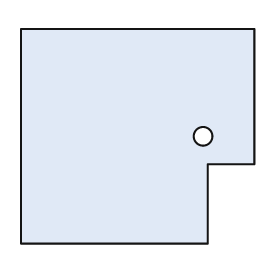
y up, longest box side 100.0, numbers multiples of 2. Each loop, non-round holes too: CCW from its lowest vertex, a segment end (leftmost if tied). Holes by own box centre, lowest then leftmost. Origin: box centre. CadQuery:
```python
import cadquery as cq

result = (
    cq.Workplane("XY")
    .moveTo(-50.0, -46.0)
    .lineTo(30.0, -46.0)
    .lineTo(30.0, -12.0)
    .lineTo(50.0, -12.0)
    .lineTo(50.0, 46.0)
    .lineTo(-50.0, 46.0)
    .close()
    .moveTo(28.0, 0.0)
    .circle(4.0)
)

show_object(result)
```